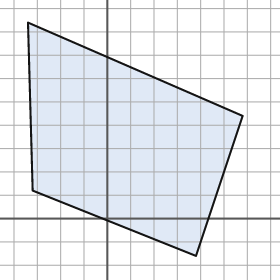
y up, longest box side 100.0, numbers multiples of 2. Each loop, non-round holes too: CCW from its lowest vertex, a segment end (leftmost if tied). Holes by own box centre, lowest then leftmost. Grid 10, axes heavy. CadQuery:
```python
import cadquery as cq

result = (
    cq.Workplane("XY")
    .moveTo(38.0, -16.0)
    .lineTo(58.0, 44.0)
    .lineTo(-34.0, 84.0)
    .lineTo(-32.0, 12.0)
    .close()
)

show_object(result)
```